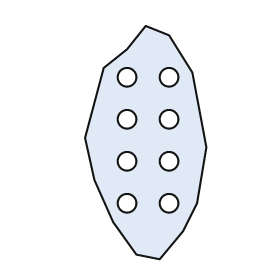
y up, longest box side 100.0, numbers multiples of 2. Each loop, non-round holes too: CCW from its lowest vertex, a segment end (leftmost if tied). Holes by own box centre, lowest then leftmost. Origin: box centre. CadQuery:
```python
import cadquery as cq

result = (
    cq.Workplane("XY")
    .moveTo(6.0, -50.0)
    .lineTo(16.0, -38.0)
    .lineTo(22.0, -26.0)
    .lineTo(26.0, -2.0)
    .lineTo(20.0, 30.0)
    .lineTo(10.0, 46.0)
    .lineTo(0.0, 50.0)
    .lineTo(-8.0, 40.0)
    .lineTo(-18.0, 32.0)
    .lineTo(-26.0, 2.0)
    .lineTo(-22.0, -16.0)
    .lineTo(-14.0, -34.0)
    .lineTo(-4.0, -48.0)
    .close()
    .moveTo(-8.0, -26.0)
    .circle(4.0)
    .moveTo(10.0, -26.0)
    .circle(4.0)
    .moveTo(-8.0, -8.0)
    .circle(4.0)
    .moveTo(10.0, -8.0)
    .circle(4.0)
    .moveTo(-8.0, 10.0)
    .circle(4.0)
    .moveTo(10.0, 10.0)
    .circle(4.0)
    .moveTo(-8.0, 28.0)
    .circle(4.0)
    .moveTo(10.0, 28.0)
    .circle(4.0)
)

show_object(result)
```